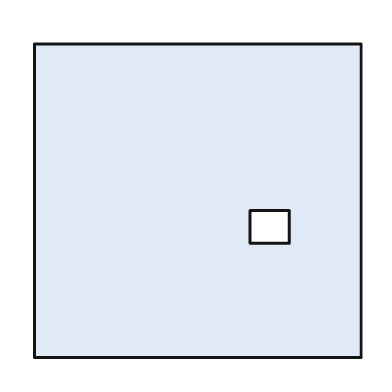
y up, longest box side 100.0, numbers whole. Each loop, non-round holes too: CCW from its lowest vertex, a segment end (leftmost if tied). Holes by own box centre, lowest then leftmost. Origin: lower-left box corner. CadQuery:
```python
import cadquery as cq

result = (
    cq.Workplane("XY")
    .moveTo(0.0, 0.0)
    .lineTo(100.0, 0.0)
    .lineTo(100.0, 96.0)
    .lineTo(0.0, 96.0)
    .close()
    .moveTo(66.0, 35.0)
    .lineTo(78.0, 35.0)
    .lineTo(78.0, 45.0)
    .lineTo(66.0, 45.0)
    .close()
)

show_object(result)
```